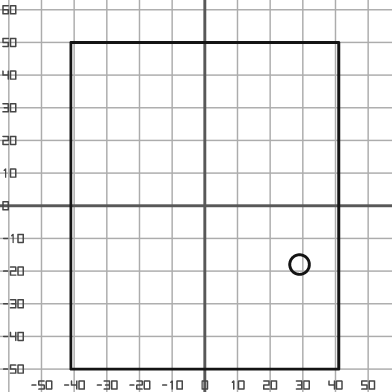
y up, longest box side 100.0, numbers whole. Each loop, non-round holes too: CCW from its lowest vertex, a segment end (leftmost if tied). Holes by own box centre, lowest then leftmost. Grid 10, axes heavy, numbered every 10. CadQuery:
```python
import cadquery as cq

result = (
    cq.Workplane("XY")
    .moveTo(-41.0, -50.0)
    .lineTo(41.0, -50.0)
    .lineTo(41.0, 50.0)
    .lineTo(-41.0, 50.0)
    .close()
    .moveTo(29.0, -18.0)
    .circle(3.0)
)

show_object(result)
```